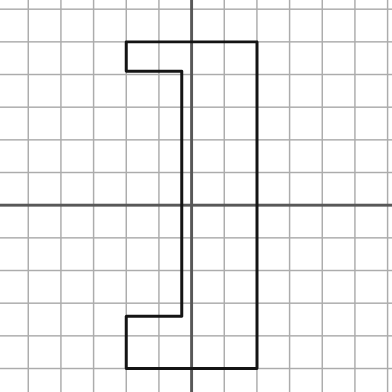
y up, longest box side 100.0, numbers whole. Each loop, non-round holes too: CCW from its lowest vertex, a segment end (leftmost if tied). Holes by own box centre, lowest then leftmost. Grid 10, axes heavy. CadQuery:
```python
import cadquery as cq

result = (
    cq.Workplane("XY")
    .moveTo(-20.0, -50.0)
    .lineTo(20.0, -50.0)
    .lineTo(20.0, 50.0)
    .lineTo(-20.0, 50.0)
    .lineTo(-20.0, 41.0)
    .lineTo(-3.0, 41.0)
    .lineTo(-3.0, -34.0)
    .lineTo(-20.0, -34.0)
    .close()
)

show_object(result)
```